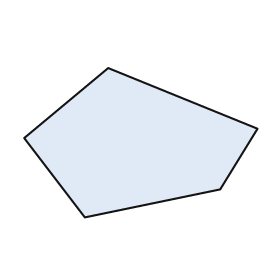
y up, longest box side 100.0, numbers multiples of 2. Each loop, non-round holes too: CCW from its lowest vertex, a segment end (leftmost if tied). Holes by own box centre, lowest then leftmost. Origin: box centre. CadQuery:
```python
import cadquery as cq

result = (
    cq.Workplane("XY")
    .moveTo(-24.0, -32.0)
    .lineTo(34.0, -20.0)
    .lineTo(50.0, 6.0)
    .lineTo(-14.0, 32.0)
    .lineTo(-50.0, 2.0)
    .close()
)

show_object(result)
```